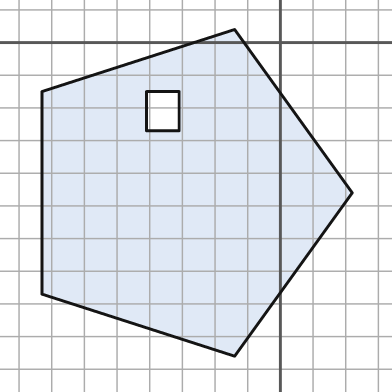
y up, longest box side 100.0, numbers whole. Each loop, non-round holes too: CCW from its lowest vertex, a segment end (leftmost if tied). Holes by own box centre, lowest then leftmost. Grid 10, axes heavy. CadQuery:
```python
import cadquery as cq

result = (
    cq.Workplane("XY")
    .moveTo(-14.0, -96.0)
    .lineTo(22.0, -46.0)
    .lineTo(-14.0, 4.0)
    .lineTo(-73.0, -15.0)
    .lineTo(-73.0, -77.0)
    .close()
    .moveTo(-41.0, -27.0)
    .lineTo(-31.0, -27.0)
    .lineTo(-31.0, -15.0)
    .lineTo(-41.0, -15.0)
    .close()
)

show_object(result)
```